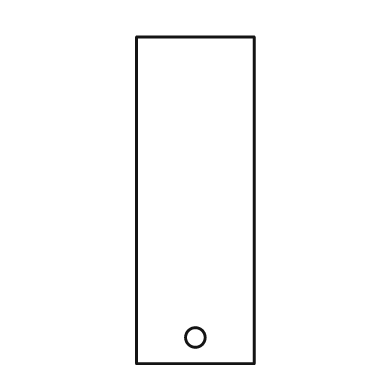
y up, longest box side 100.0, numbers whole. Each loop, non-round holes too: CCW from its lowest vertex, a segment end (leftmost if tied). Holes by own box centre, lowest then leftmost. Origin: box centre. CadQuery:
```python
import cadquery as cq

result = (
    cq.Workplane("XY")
    .moveTo(-18.0, -50.0)
    .lineTo(18.0, -50.0)
    .lineTo(18.0, 50.0)
    .lineTo(-18.0, 50.0)
    .close()
    .moveTo(0.0, -42.0)
    .circle(3.0)
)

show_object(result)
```